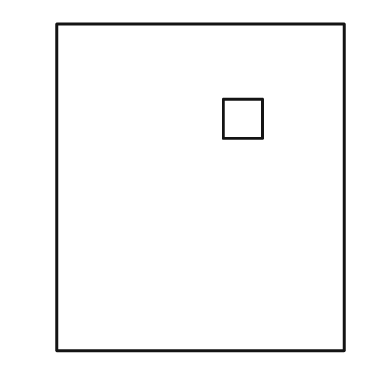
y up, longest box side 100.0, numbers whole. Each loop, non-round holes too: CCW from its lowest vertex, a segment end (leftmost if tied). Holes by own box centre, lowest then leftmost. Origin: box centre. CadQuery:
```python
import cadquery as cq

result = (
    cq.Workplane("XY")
    .moveTo(-44.0, -50.0)
    .lineTo(44.0, -50.0)
    .lineTo(44.0, 50.0)
    .lineTo(-44.0, 50.0)
    .close()
    .moveTo(7.0, 15.0)
    .lineTo(19.0, 15.0)
    .lineTo(19.0, 27.0)
    .lineTo(7.0, 27.0)
    .close()
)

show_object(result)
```